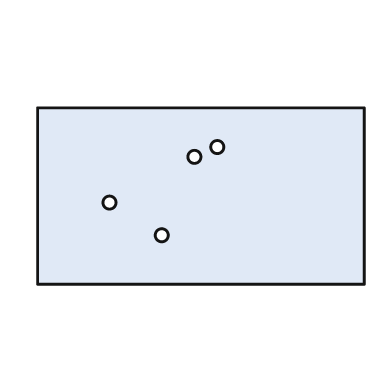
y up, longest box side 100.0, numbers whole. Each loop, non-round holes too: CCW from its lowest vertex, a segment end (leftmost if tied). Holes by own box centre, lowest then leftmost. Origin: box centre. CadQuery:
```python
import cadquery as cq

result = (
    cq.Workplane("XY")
    .moveTo(-50.0, -27.0)
    .lineTo(50.0, -27.0)
    .lineTo(50.0, 27.0)
    .lineTo(-50.0, 27.0)
    .close()
    .moveTo(-12.0, -12.0)
    .circle(2.0)
    .moveTo(-28.0, -2.0)
    .circle(2.0)
    .moveTo(-2.0, 12.0)
    .circle(2.0)
    .moveTo(5.0, 15.0)
    .circle(2.0)
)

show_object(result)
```